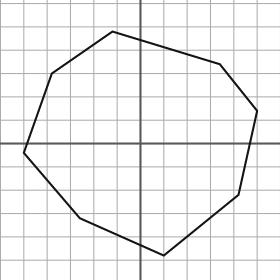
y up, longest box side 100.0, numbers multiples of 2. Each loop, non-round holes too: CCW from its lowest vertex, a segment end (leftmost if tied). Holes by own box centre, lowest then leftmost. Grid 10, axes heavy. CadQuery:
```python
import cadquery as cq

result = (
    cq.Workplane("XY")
    .moveTo(10.0, -48.0)
    .lineTo(42.0, -22.0)
    .lineTo(50.0, 14.0)
    .lineTo(34.0, 34.0)
    .lineTo(-12.0, 48.0)
    .lineTo(-38.0, 30.0)
    .lineTo(-50.0, -4.0)
    .lineTo(-26.0, -32.0)
    .close()
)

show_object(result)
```